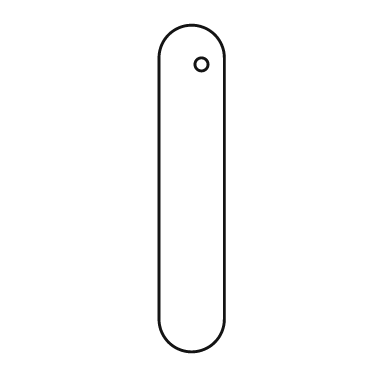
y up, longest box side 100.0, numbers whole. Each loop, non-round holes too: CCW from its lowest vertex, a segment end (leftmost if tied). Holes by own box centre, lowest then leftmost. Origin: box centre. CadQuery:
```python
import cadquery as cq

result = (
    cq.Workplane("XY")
    .moveTo(-10.0, -40.0)
    .threePointArc((0.0, -50.0), (10.0, -40.0))
    .lineTo(10.0, 40.0)
    .threePointArc((0.0, 50.0), (-10.0, 40.0))
    .close()
    .moveTo(3.0, 38.0)
    .circle(2.0)
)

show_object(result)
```